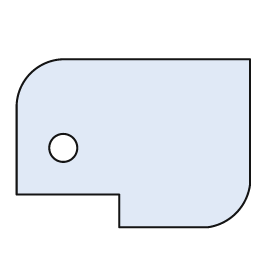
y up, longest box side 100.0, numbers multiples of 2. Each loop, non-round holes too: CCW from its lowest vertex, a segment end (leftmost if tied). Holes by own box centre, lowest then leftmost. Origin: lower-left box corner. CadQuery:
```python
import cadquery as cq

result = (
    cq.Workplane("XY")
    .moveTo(44.0, 0.0)
    .lineTo(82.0, 0.0)
    .threePointArc((94.0, 6.0), (100.0, 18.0))
    .lineTo(100.0, 72.0)
    .lineTo(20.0, 72.0)
    .threePointArc((6.0, 66.0), (0.0, 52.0))
    .lineTo(0.0, 14.0)
    .lineTo(44.0, 14.0)
    .close()
    .moveTo(20.0, 34.0)
    .circle(6.0)
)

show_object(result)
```